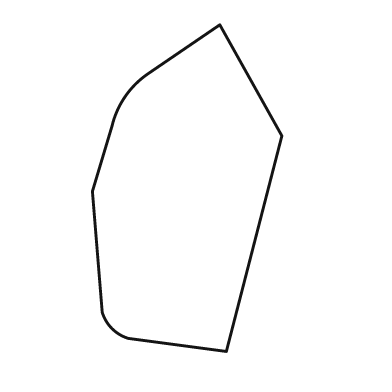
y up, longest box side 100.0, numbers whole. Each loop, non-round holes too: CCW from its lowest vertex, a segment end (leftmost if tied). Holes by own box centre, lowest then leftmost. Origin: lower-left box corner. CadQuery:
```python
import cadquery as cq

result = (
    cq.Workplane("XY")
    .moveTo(41.0, 0.0)
    .lineTo(58.0, 66.0)
    .lineTo(39.0, 100.0)
    .lineTo(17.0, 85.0)
    .threePointArc((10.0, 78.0), (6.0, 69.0))
    .lineTo(0.0, 49.0)
    .lineTo(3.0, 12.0)
    .threePointArc((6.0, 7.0), (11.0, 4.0))
    .close()
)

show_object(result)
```